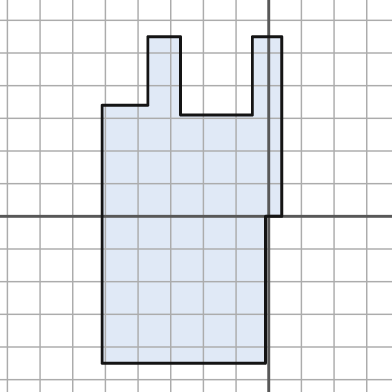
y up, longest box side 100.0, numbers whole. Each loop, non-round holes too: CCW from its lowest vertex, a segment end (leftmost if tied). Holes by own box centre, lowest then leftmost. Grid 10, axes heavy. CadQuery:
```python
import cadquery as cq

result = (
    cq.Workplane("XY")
    .moveTo(-51.0, -45.0)
    .lineTo(-1.0, -45.0)
    .lineTo(-1.0, 0.0)
    .lineTo(4.0, 0.0)
    .lineTo(4.0, 55.0)
    .lineTo(-5.0, 55.0)
    .lineTo(-5.0, 31.0)
    .lineTo(-27.0, 31.0)
    .lineTo(-27.0, 55.0)
    .lineTo(-37.0, 55.0)
    .lineTo(-37.0, 34.0)
    .lineTo(-51.0, 34.0)
    .close()
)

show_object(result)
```